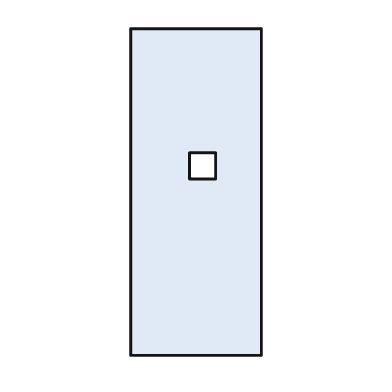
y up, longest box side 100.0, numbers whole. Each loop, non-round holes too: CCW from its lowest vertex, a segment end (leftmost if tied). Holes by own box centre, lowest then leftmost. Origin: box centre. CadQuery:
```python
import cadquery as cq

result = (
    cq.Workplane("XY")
    .moveTo(-20.0, -50.0)
    .lineTo(20.0, -50.0)
    .lineTo(20.0, 50.0)
    .lineTo(-20.0, 50.0)
    .close()
    .moveTo(-2.0, 4.0)
    .lineTo(6.0, 4.0)
    .lineTo(6.0, 12.0)
    .lineTo(-2.0, 12.0)
    .close()
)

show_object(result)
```